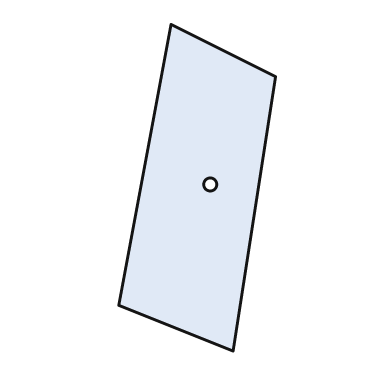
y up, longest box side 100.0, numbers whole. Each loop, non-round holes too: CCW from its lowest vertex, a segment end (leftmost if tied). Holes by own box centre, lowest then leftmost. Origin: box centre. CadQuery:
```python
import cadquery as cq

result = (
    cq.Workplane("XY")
    .moveTo(11.0, -50.0)
    .lineTo(24.0, 34.0)
    .lineTo(-8.0, 50.0)
    .lineTo(-24.0, -36.0)
    .close()
    .moveTo(4.0, 1.0)
    .circle(2.0)
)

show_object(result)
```